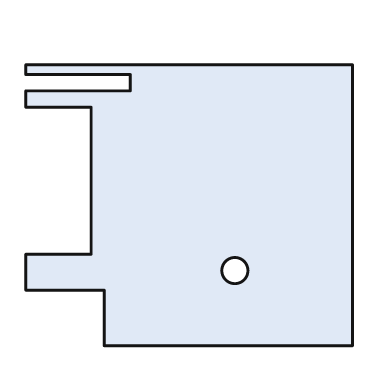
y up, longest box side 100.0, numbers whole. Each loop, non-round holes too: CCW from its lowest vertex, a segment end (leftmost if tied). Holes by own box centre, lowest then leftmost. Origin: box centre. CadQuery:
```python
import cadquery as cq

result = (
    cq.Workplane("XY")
    .moveTo(-26.0, -43.0)
    .lineTo(50.0, -43.0)
    .lineTo(50.0, 43.0)
    .lineTo(-50.0, 43.0)
    .lineTo(-50.0, 40.0)
    .lineTo(-18.0, 40.0)
    .lineTo(-18.0, 35.0)
    .lineTo(-50.0, 35.0)
    .lineTo(-50.0, 30.0)
    .lineTo(-30.0, 30.0)
    .lineTo(-30.0, -15.0)
    .lineTo(-50.0, -15.0)
    .lineTo(-50.0, -26.0)
    .lineTo(-26.0, -26.0)
    .close()
    .moveTo(14.0, -20.0)
    .circle(4.0)
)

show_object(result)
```